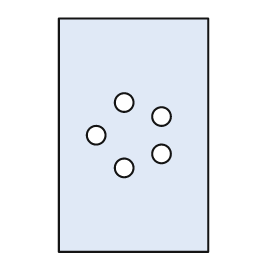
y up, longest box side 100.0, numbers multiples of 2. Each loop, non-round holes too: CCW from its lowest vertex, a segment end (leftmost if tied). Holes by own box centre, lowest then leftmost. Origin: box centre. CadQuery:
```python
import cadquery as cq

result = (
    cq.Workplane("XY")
    .moveTo(-32.0, -50.0)
    .lineTo(32.0, -50.0)
    .lineTo(32.0, 50.0)
    .lineTo(-32.0, 50.0)
    .close()
    .moveTo(-4.0, -14.0)
    .circle(4.0)
    .moveTo(12.0, -8.0)
    .circle(4.0)
    .moveTo(-16.0, 0.0)
    .circle(4.0)
    .moveTo(12.0, 8.0)
    .circle(4.0)
    .moveTo(-4.0, 14.0)
    .circle(4.0)
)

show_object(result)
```